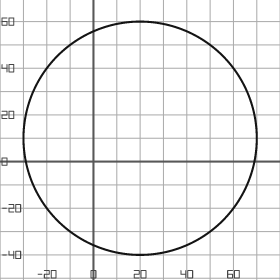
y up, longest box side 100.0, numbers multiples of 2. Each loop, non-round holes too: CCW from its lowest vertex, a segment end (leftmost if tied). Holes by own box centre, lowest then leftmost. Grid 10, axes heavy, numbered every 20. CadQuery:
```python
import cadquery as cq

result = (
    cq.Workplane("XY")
    .moveTo(20.0, 10.0)
    .circle(50.0)
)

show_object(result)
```